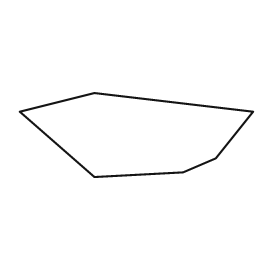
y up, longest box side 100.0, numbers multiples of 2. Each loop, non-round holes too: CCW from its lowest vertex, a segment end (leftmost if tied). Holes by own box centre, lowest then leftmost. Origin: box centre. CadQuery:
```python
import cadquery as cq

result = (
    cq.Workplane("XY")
    .moveTo(-18.0, -18.0)
    .lineTo(20.0, -16.0)
    .lineTo(34.0, -10.0)
    .lineTo(50.0, 10.0)
    .lineTo(-18.0, 18.0)
    .lineTo(-50.0, 10.0)
    .close()
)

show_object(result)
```